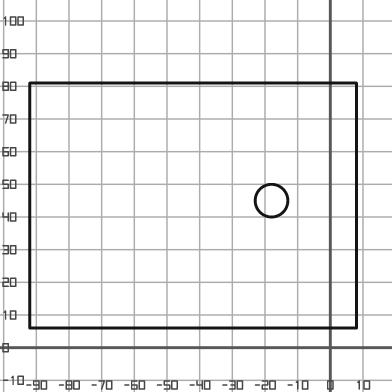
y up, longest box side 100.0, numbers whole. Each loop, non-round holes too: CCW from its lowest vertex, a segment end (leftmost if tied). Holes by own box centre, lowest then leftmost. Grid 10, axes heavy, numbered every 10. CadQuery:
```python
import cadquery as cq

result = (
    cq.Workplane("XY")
    .moveTo(-92.0, 6.0)
    .lineTo(8.0, 6.0)
    .lineTo(8.0, 81.0)
    .lineTo(-92.0, 81.0)
    .close()
    .moveTo(-18.0, 45.0)
    .circle(5.0)
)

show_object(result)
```